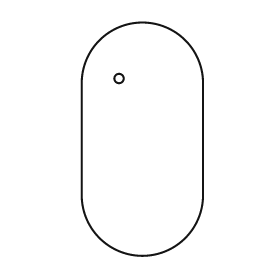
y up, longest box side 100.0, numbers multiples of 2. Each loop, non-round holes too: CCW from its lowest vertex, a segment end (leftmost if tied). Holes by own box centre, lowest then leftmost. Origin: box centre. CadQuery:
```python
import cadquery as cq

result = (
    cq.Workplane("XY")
    .moveTo(-26.0, -24.0)
    .threePointArc((0.0, -50.0), (26.0, -24.0))
    .lineTo(26.0, 24.0)
    .threePointArc((0.0, 50.0), (-26.0, 24.0))
    .close()
    .moveTo(-10.0, 26.0)
    .circle(2.0)
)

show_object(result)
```